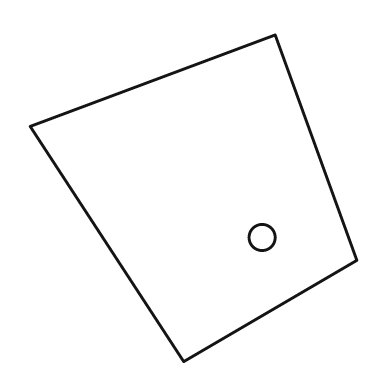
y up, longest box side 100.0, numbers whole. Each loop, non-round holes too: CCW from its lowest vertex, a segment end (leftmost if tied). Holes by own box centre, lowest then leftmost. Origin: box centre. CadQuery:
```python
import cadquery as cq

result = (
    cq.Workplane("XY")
    .moveTo(-3.0, -50.0)
    .lineTo(50.0, -19.0)
    .lineTo(25.0, 50.0)
    .lineTo(-50.0, 22.0)
    .close()
    .moveTo(21.0, -12.0)
    .circle(4.0)
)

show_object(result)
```